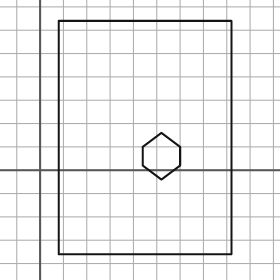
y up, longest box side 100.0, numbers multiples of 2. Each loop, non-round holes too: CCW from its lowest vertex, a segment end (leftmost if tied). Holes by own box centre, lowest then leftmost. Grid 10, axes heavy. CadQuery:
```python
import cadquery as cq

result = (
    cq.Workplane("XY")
    .moveTo(8.0, -36.0)
    .lineTo(82.0, -36.0)
    .lineTo(82.0, 64.0)
    .lineTo(8.0, 64.0)
    .close()
    .moveTo(52.0, -4.0)
    .lineTo(60.0, 2.0)
    .lineTo(60.0, 10.0)
    .lineTo(52.0, 16.0)
    .lineTo(44.0, 10.0)
    .lineTo(44.0, 2.0)
    .close()
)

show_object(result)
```